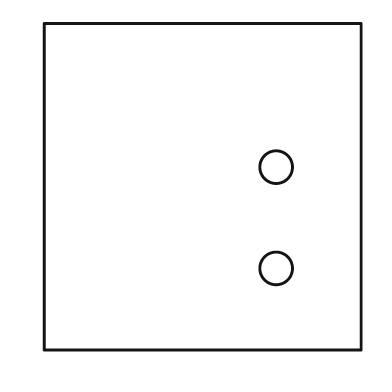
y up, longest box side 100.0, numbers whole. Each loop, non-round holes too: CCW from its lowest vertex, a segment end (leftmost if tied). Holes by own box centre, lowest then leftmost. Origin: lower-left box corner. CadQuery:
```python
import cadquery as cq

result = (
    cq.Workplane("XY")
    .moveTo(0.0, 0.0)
    .lineTo(97.0, 0.0)
    .lineTo(97.0, 100.0)
    .lineTo(0.0, 100.0)
    .close()
    .moveTo(71.0, 25.0)
    .circle(5.0)
    .moveTo(71.0, 56.0)
    .circle(5.0)
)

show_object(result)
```